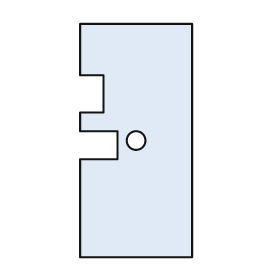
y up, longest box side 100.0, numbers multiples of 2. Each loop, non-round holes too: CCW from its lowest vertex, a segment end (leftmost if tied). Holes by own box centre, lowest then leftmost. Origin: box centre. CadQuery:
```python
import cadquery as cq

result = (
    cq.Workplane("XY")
    .moveTo(-24.0, -50.0)
    .lineTo(24.0, -50.0)
    .lineTo(24.0, 50.0)
    .lineTo(-24.0, 50.0)
    .lineTo(-24.0, 28.0)
    .lineTo(-14.0, 28.0)
    .lineTo(-14.0, 12.0)
    .lineTo(-24.0, 12.0)
    .lineTo(-24.0, 4.0)
    .lineTo(-8.0, 4.0)
    .lineTo(-8.0, -8.0)
    .lineTo(-24.0, -8.0)
    .close()
    .moveTo(0.0, 0.0)
    .circle(4.0)
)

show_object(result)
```